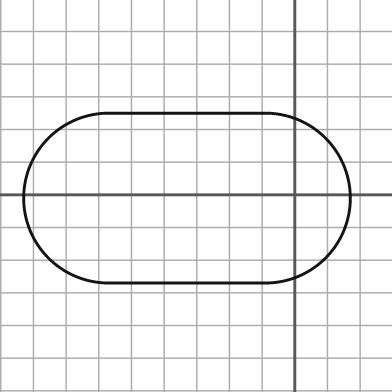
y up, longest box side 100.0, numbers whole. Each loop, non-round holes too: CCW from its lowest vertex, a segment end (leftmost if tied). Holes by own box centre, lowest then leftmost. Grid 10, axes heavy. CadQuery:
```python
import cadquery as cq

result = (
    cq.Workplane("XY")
    .moveTo(-57.0, -27.0)
    .lineTo(-9.0, -27.0)
    .threePointArc((17.0, -1.0), (-9.0, 25.0))
    .lineTo(-57.0, 25.0)
    .threePointArc((-83.0, -1.0), (-57.0, -27.0))
    .close()
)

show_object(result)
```